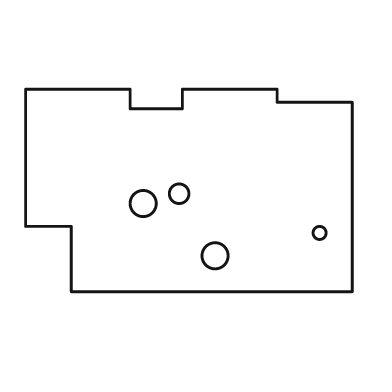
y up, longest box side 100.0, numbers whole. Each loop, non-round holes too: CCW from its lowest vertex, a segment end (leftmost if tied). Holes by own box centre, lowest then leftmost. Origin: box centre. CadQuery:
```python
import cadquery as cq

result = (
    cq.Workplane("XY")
    .moveTo(-36.0, -31.0)
    .lineTo(50.0, -31.0)
    .lineTo(50.0, 27.0)
    .lineTo(27.0, 27.0)
    .lineTo(27.0, 31.0)
    .lineTo(-2.0, 31.0)
    .lineTo(-2.0, 25.0)
    .lineTo(-18.0, 25.0)
    .lineTo(-18.0, 31.0)
    .lineTo(-50.0, 31.0)
    .lineTo(-50.0, -11.0)
    .lineTo(-36.0, -11.0)
    .close()
    .moveTo(8.0, -20.0)
    .circle(4.0)
    .moveTo(40.0, -13.0)
    .circle(2.0)
    .moveTo(-14.0, -4.0)
    .circle(4.0)
    .moveTo(-3.0, -1.0)
    .circle(3.0)
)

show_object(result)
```